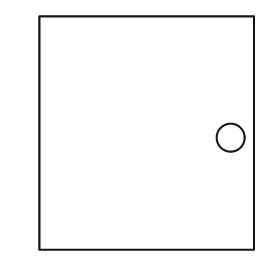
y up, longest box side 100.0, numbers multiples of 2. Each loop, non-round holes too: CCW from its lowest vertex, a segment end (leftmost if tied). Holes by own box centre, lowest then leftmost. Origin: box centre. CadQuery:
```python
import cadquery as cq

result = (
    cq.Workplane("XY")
    .moveTo(-46.0, -50.0)
    .lineTo(46.0, -50.0)
    .lineTo(46.0, 50.0)
    .lineTo(-46.0, 50.0)
    .close()
    .moveTo(36.0, -2.0)
    .circle(6.0)
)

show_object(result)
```